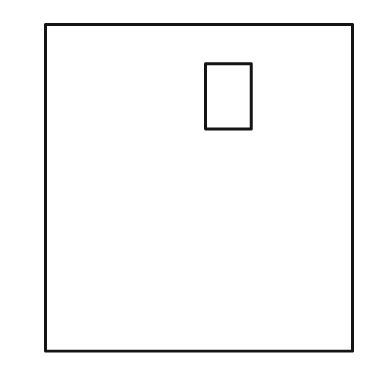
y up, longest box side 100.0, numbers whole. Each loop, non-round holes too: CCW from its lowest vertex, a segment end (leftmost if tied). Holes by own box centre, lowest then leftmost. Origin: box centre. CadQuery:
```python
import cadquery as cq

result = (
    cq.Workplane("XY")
    .moveTo(-47.0, -50.0)
    .lineTo(47.0, -50.0)
    .lineTo(47.0, 50.0)
    .lineTo(-47.0, 50.0)
    .close()
    .moveTo(2.0, 18.0)
    .lineTo(16.0, 18.0)
    .lineTo(16.0, 38.0)
    .lineTo(2.0, 38.0)
    .close()
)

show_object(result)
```